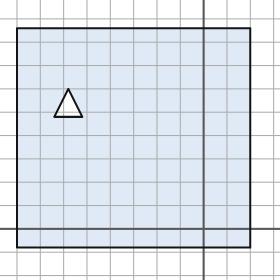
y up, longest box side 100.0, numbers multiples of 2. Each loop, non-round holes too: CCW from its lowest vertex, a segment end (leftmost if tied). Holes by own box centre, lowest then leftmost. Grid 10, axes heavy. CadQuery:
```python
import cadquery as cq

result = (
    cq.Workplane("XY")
    .moveTo(-80.0, -8.0)
    .lineTo(20.0, -8.0)
    .lineTo(20.0, 86.0)
    .lineTo(-80.0, 86.0)
    .close()
    .moveTo(-64.0, 48.0)
    .lineTo(-52.0, 48.0)
    .lineTo(-58.0, 60.0)
    .close()
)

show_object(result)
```